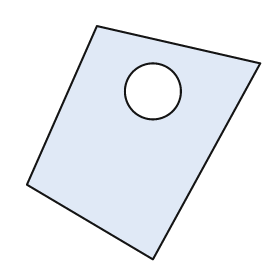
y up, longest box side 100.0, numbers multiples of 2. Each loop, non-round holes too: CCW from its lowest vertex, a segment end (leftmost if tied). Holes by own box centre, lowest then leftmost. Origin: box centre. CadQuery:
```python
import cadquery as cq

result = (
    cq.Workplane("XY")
    .moveTo(4.0, -50.0)
    .lineTo(50.0, 34.0)
    .lineTo(-20.0, 50.0)
    .lineTo(-50.0, -18.0)
    .close()
    .moveTo(4.0, 22.0)
    .circle(12.0)
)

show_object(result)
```